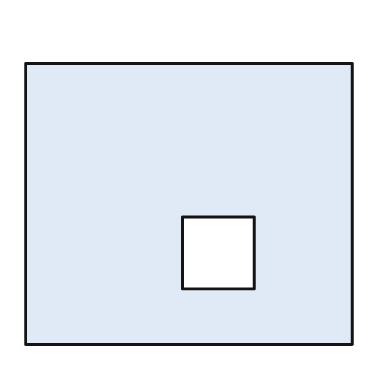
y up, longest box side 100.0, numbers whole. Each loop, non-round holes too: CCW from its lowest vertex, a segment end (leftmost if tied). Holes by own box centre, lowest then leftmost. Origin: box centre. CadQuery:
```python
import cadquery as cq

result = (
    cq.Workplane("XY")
    .moveTo(-50.0, -43.0)
    .lineTo(50.0, -43.0)
    .lineTo(50.0, 43.0)
    .lineTo(-50.0, 43.0)
    .close()
    .moveTo(-2.0, -26.0)
    .lineTo(20.0, -26.0)
    .lineTo(20.0, -4.0)
    .lineTo(-2.0, -4.0)
    .close()
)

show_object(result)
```